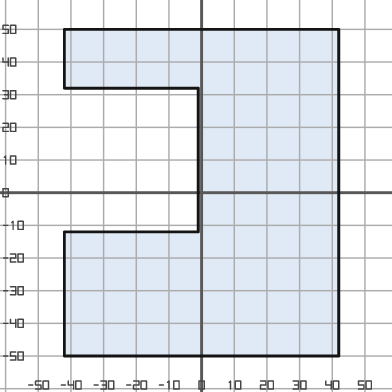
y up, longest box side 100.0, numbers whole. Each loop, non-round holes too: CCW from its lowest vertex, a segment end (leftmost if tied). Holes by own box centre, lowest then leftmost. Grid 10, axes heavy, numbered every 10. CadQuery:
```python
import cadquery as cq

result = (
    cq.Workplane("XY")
    .moveTo(-42.0, -50.0)
    .lineTo(42.0, -50.0)
    .lineTo(42.0, 50.0)
    .lineTo(-42.0, 50.0)
    .lineTo(-42.0, 32.0)
    .lineTo(-1.0, 32.0)
    .lineTo(-1.0, -12.0)
    .lineTo(-42.0, -12.0)
    .close()
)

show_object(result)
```